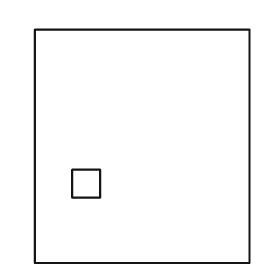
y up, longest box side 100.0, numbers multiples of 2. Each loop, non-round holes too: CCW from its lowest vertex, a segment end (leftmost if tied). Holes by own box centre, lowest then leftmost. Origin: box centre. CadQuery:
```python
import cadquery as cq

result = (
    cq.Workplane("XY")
    .moveTo(-46.0, -50.0)
    .lineTo(46.0, -50.0)
    .lineTo(46.0, 50.0)
    .lineTo(-46.0, 50.0)
    .close()
    .moveTo(-30.0, -22.0)
    .lineTo(-18.0, -22.0)
    .lineTo(-18.0, -10.0)
    .lineTo(-30.0, -10.0)
    .close()
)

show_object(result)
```